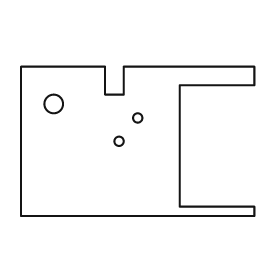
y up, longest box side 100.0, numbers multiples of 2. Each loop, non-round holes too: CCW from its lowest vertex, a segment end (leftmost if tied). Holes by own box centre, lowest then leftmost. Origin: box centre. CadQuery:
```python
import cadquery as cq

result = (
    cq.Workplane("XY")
    .moveTo(-50.0, -32.0)
    .lineTo(50.0, -32.0)
    .lineTo(50.0, -28.0)
    .lineTo(18.0, -28.0)
    .lineTo(18.0, 24.0)
    .lineTo(50.0, 24.0)
    .lineTo(50.0, 32.0)
    .lineTo(-6.0, 32.0)
    .lineTo(-6.0, 20.0)
    .lineTo(-14.0, 20.0)
    .lineTo(-14.0, 32.0)
    .lineTo(-50.0, 32.0)
    .close()
    .moveTo(-8.0, 0.0)
    .circle(2.0)
    .moveTo(0.0, 10.0)
    .circle(2.0)
    .moveTo(-36.0, 16.0)
    .circle(4.0)
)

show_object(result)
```